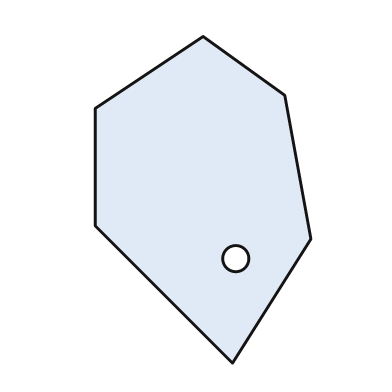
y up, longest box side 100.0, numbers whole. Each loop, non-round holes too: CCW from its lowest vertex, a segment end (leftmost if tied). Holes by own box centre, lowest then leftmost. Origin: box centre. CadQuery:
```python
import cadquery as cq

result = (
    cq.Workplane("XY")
    .moveTo(9.0, -50.0)
    .lineTo(33.0, -12.0)
    .lineTo(25.0, 32.0)
    .lineTo(0.0, 50.0)
    .lineTo(-33.0, 28.0)
    .lineTo(-33.0, -8.0)
    .close()
    .moveTo(10.0, -18.0)
    .circle(4.0)
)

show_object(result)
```